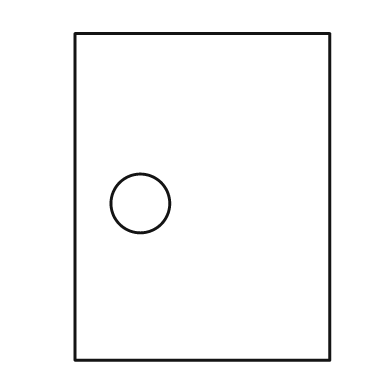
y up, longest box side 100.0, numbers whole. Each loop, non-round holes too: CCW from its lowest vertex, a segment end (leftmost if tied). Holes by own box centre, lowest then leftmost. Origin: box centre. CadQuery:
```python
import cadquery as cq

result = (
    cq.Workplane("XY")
    .moveTo(-39.0, -50.0)
    .lineTo(39.0, -50.0)
    .lineTo(39.0, 50.0)
    .lineTo(-39.0, 50.0)
    .close()
    .moveTo(-19.0, -2.0)
    .circle(9.0)
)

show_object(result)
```